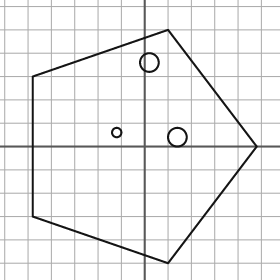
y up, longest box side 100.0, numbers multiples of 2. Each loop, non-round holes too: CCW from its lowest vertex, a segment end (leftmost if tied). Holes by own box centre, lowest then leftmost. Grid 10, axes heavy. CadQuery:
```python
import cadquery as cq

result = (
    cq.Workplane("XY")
    .moveTo(10.0, -50.0)
    .lineTo(48.0, 0.0)
    .lineTo(10.0, 50.0)
    .lineTo(-48.0, 30.0)
    .lineTo(-48.0, -30.0)
    .close()
    .moveTo(14.0, 4.0)
    .circle(4.0)
    .moveTo(-12.0, 6.0)
    .circle(2.0)
    .moveTo(2.0, 36.0)
    .circle(4.0)
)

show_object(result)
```